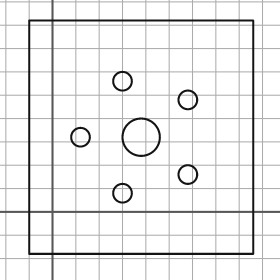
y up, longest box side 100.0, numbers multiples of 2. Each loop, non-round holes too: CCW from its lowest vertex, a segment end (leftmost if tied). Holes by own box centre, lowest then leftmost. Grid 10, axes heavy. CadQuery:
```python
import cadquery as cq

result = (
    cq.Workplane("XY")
    .moveTo(-10.0, -18.0)
    .lineTo(86.0, -18.0)
    .lineTo(86.0, 82.0)
    .lineTo(-10.0, 82.0)
    .close()
    .moveTo(30.0, 8.0)
    .circle(4.0)
    .moveTo(58.0, 16.0)
    .circle(4.0)
    .moveTo(12.0, 32.0)
    .circle(4.0)
    .moveTo(38.0, 32.0)
    .circle(8.0)
    .moveTo(58.0, 48.0)
    .circle(4.0)
    .moveTo(30.0, 56.0)
    .circle(4.0)
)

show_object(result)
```